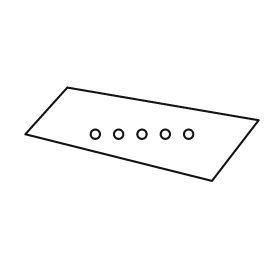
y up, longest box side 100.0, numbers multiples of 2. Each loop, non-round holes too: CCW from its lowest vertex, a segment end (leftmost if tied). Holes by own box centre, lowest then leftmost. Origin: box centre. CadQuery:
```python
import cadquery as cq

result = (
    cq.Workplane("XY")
    .moveTo(30.0, -20.0)
    .lineTo(50.0, 6.0)
    .lineTo(-32.0, 20.0)
    .lineTo(-50.0, 0.0)
    .close()
    .moveTo(-20.0, 0.0)
    .circle(2.0)
    .moveTo(-10.0, 0.0)
    .circle(2.0)
    .moveTo(0.0, 0.0)
    .circle(2.0)
    .moveTo(10.0, 0.0)
    .circle(2.0)
    .moveTo(20.0, 0.0)
    .circle(2.0)
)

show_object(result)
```